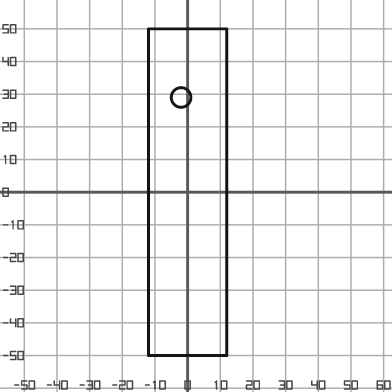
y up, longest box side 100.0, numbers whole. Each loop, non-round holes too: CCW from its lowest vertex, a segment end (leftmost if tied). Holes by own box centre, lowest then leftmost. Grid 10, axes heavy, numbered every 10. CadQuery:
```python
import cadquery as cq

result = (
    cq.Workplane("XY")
    .moveTo(-12.0, -50.0)
    .lineTo(12.0, -50.0)
    .lineTo(12.0, 50.0)
    .lineTo(-12.0, 50.0)
    .close()
    .moveTo(-2.0, 29.0)
    .circle(3.0)
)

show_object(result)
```